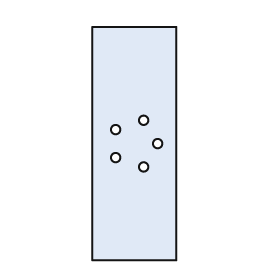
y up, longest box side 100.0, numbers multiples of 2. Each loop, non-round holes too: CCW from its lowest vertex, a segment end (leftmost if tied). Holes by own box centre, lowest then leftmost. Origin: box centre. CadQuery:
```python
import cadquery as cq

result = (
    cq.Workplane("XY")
    .moveTo(-18.0, -50.0)
    .lineTo(18.0, -50.0)
    .lineTo(18.0, 50.0)
    .lineTo(-18.0, 50.0)
    .close()
    .moveTo(4.0, -10.0)
    .circle(2.0)
    .moveTo(-8.0, -6.0)
    .circle(2.0)
    .moveTo(10.0, 0.0)
    .circle(2.0)
    .moveTo(-8.0, 6.0)
    .circle(2.0)
    .moveTo(4.0, 10.0)
    .circle(2.0)
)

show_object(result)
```